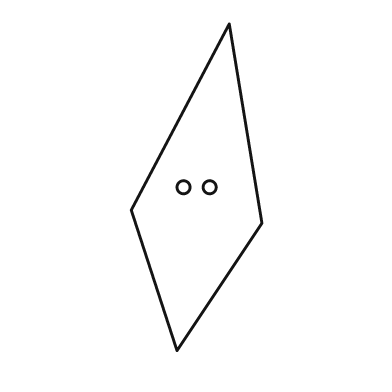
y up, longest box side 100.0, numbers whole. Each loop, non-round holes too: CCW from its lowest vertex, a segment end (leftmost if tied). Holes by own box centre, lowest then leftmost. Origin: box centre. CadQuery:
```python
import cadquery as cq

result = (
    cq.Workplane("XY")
    .moveTo(-6.0, -50.0)
    .lineTo(20.0, -11.0)
    .lineTo(10.0, 50.0)
    .lineTo(-20.0, -7.0)
    .close()
    .moveTo(-4.0, 0.0)
    .circle(2.0)
    .moveTo(4.0, 0.0)
    .circle(2.0)
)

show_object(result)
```